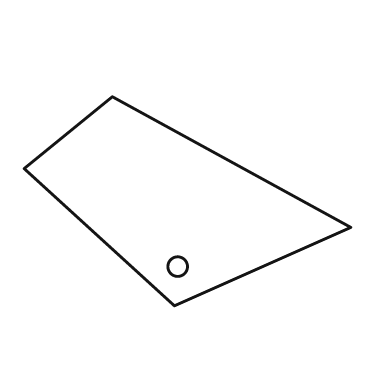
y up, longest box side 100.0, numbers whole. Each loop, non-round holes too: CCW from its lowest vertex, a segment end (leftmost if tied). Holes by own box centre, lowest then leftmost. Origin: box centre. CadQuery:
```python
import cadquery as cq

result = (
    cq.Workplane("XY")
    .moveTo(-4.0, -32.0)
    .lineTo(50.0, -8.0)
    .lineTo(-23.0, 32.0)
    .lineTo(-50.0, 10.0)
    .close()
    .moveTo(-3.0, -20.0)
    .circle(3.0)
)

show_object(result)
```